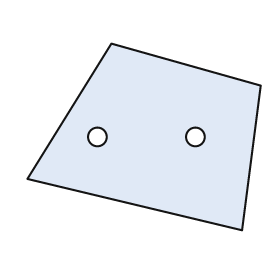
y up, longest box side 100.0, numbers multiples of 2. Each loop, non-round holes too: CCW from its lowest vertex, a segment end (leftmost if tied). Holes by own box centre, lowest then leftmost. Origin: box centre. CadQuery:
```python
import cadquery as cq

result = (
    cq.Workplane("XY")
    .moveTo(42.0, -40.0)
    .lineTo(50.0, 22.0)
    .lineTo(-14.0, 40.0)
    .lineTo(-50.0, -18.0)
    .close()
    .moveTo(-20.0, 0.0)
    .circle(4.0)
    .moveTo(22.0, 0.0)
    .circle(4.0)
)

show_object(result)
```